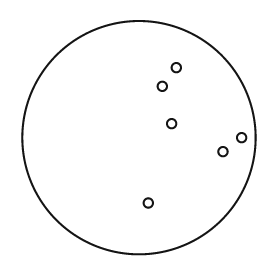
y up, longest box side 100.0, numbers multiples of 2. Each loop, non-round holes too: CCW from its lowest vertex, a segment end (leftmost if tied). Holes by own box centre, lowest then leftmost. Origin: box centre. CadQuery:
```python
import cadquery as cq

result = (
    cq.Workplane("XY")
    .moveTo(0.0, 0.0)
    .circle(50.0)
    .moveTo(4.0, -28.0)
    .circle(2.0)
    .moveTo(36.0, -6.0)
    .circle(2.0)
    .moveTo(44.0, 0.0)
    .circle(2.0)
    .moveTo(14.0, 6.0)
    .circle(2.0)
    .moveTo(10.0, 22.0)
    .circle(2.0)
    .moveTo(16.0, 30.0)
    .circle(2.0)
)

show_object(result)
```